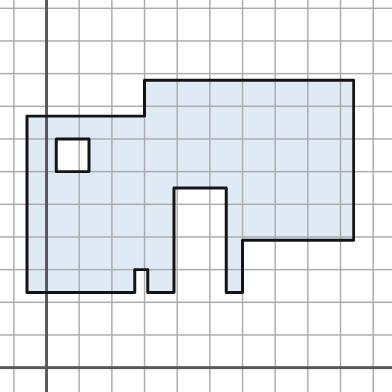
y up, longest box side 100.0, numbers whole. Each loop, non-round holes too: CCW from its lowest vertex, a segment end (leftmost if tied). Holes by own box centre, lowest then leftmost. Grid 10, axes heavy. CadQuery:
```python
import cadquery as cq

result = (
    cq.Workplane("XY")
    .moveTo(-6.0, 23.0)
    .lineTo(27.0, 23.0)
    .lineTo(27.0, 30.0)
    .lineTo(31.0, 30.0)
    .lineTo(31.0, 23.0)
    .lineTo(39.0, 23.0)
    .lineTo(39.0, 55.0)
    .lineTo(55.0, 55.0)
    .lineTo(55.0, 23.0)
    .lineTo(60.0, 23.0)
    .lineTo(60.0, 39.0)
    .lineTo(94.0, 39.0)
    .lineTo(94.0, 88.0)
    .lineTo(30.0, 88.0)
    .lineTo(30.0, 77.0)
    .lineTo(-6.0, 77.0)
    .close()
    .moveTo(3.0, 60.0)
    .lineTo(13.0, 60.0)
    .lineTo(13.0, 70.0)
    .lineTo(3.0, 70.0)
    .close()
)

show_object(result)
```